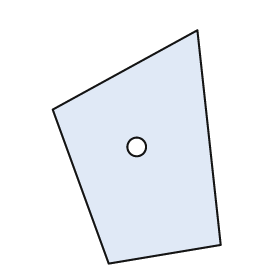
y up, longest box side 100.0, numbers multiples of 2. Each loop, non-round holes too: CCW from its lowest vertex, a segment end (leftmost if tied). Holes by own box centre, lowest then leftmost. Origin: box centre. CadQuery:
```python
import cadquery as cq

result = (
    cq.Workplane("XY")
    .moveTo(-12.0, -50.0)
    .lineTo(36.0, -42.0)
    .lineTo(26.0, 50.0)
    .lineTo(-36.0, 16.0)
    .close()
    .moveTo(0.0, 0.0)
    .circle(4.0)
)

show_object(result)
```